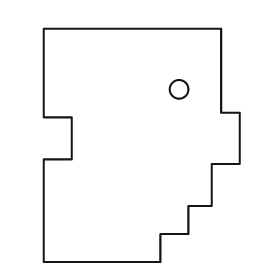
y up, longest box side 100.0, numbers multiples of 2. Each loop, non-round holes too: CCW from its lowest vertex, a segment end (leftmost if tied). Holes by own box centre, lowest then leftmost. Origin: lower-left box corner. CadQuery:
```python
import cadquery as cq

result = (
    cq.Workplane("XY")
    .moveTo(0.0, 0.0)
    .lineTo(50.0, 0.0)
    .lineTo(50.0, 12.0)
    .lineTo(62.0, 12.0)
    .lineTo(62.0, 24.0)
    .lineTo(72.0, 24.0)
    .lineTo(72.0, 42.0)
    .lineTo(84.0, 42.0)
    .lineTo(84.0, 64.0)
    .lineTo(76.0, 64.0)
    .lineTo(76.0, 100.0)
    .lineTo(0.0, 100.0)
    .lineTo(0.0, 62.0)
    .lineTo(12.0, 62.0)
    .lineTo(12.0, 44.0)
    .lineTo(0.0, 44.0)
    .close()
    .moveTo(58.0, 74.0)
    .circle(4.0)
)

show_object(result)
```